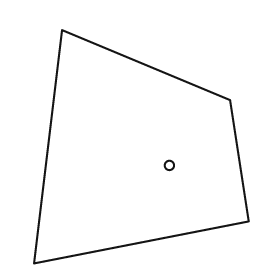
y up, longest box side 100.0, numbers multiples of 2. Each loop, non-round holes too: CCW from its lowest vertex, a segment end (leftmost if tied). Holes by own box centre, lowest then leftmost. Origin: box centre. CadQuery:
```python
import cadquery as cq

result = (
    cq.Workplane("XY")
    .moveTo(-46.0, -50.0)
    .lineTo(46.0, -32.0)
    .lineTo(38.0, 20.0)
    .lineTo(-34.0, 50.0)
    .close()
    .moveTo(12.0, -8.0)
    .circle(2.0)
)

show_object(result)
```